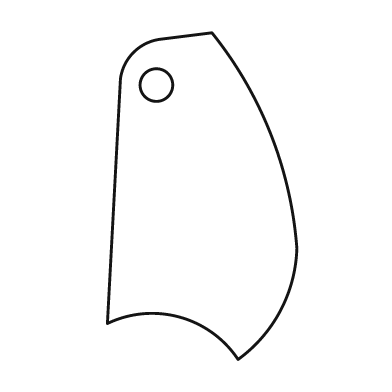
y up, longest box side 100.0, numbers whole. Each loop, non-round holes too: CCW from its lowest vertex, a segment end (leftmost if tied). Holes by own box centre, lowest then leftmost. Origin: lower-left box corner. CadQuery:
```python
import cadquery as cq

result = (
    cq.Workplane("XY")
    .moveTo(40.0, 0.0)
    .threePointArc((53.0, 15.0), (58.0, 34.0))
    .threePointArc((50.0, 69.0), (32.0, 100.0))
    .lineTo(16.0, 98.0)
    .threePointArc((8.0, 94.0), (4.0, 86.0))
    .lineTo(0.0, 11.0)
    .threePointArc((22.0, 13.0), (40.0, 0.0))
    .close()
    .moveTo(15.0, 84.0)
    .circle(5.0)
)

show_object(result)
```